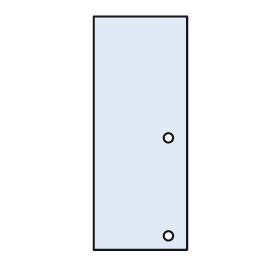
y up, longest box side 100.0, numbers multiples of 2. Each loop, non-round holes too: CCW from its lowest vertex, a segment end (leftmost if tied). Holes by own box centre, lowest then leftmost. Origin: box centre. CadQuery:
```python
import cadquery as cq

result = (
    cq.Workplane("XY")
    .moveTo(-20.0, -50.0)
    .lineTo(20.0, -50.0)
    .lineTo(20.0, 50.0)
    .lineTo(-20.0, 50.0)
    .close()
    .moveTo(12.0, -44.0)
    .circle(2.0)
    .moveTo(12.0, -2.0)
    .circle(2.0)
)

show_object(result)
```